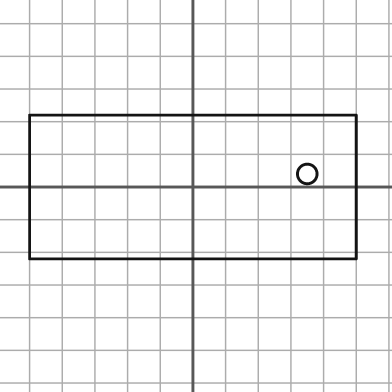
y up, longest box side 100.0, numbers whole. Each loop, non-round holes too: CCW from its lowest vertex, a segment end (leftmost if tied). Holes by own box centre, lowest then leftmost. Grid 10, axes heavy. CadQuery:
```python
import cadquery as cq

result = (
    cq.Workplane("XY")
    .moveTo(-50.0, -22.0)
    .lineTo(50.0, -22.0)
    .lineTo(50.0, 22.0)
    .lineTo(-50.0, 22.0)
    .close()
    .moveTo(35.0, 4.0)
    .circle(3.0)
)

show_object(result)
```